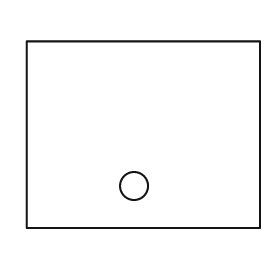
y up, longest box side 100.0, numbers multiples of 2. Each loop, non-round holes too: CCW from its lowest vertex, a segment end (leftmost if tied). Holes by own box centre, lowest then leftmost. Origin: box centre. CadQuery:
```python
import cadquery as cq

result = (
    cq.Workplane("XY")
    .moveTo(-50.0, -40.0)
    .lineTo(50.0, -40.0)
    .lineTo(50.0, 40.0)
    .lineTo(-50.0, 40.0)
    .close()
    .moveTo(-4.0, -22.0)
    .circle(6.0)
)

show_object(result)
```